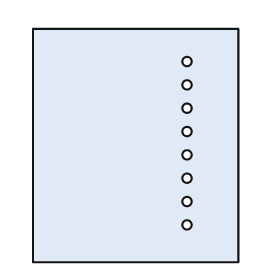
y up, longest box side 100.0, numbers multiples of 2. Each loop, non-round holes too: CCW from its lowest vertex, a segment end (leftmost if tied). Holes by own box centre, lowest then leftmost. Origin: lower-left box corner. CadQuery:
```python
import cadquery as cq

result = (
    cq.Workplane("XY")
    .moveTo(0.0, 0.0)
    .lineTo(88.0, 0.0)
    .lineTo(88.0, 100.0)
    .lineTo(0.0, 100.0)
    .close()
    .moveTo(66.0, 16.0)
    .circle(2.0)
    .moveTo(66.0, 26.0)
    .circle(2.0)
    .moveTo(66.0, 36.0)
    .circle(2.0)
    .moveTo(66.0, 46.0)
    .circle(2.0)
    .moveTo(66.0, 56.0)
    .circle(2.0)
    .moveTo(66.0, 66.0)
    .circle(2.0)
    .moveTo(66.0, 76.0)
    .circle(2.0)
    .moveTo(66.0, 86.0)
    .circle(2.0)
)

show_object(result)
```